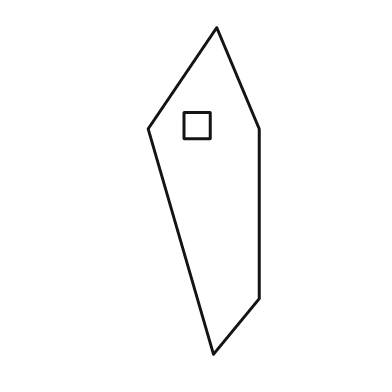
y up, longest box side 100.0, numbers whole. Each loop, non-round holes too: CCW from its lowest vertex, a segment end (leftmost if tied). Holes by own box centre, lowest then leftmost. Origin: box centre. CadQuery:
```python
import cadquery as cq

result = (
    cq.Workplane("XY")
    .moveTo(3.0, -50.0)
    .lineTo(17.0, -33.0)
    .lineTo(17.0, 19.0)
    .lineTo(4.0, 50.0)
    .lineTo(-17.0, 19.0)
    .close()
    .moveTo(-6.0, 16.0)
    .lineTo(2.0, 16.0)
    .lineTo(2.0, 24.0)
    .lineTo(-6.0, 24.0)
    .close()
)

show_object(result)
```